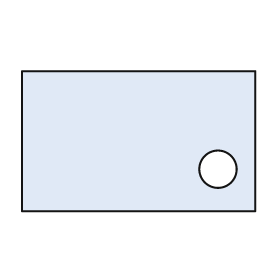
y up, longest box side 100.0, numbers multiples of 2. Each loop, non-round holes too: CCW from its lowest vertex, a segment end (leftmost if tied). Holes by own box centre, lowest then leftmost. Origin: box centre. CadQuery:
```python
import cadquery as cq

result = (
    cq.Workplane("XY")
    .moveTo(-50.0, -30.0)
    .lineTo(50.0, -30.0)
    .lineTo(50.0, 30.0)
    .lineTo(-50.0, 30.0)
    .close()
    .moveTo(34.0, -12.0)
    .circle(8.0)
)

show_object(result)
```